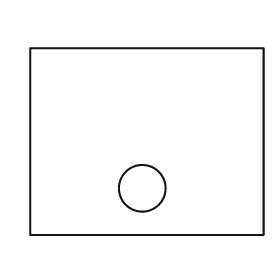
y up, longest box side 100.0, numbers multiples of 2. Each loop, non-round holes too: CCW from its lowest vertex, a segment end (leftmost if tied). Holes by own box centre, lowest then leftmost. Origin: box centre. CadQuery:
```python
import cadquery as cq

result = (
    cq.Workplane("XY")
    .moveTo(-50.0, -40.0)
    .lineTo(50.0, -40.0)
    .lineTo(50.0, 40.0)
    .lineTo(-50.0, 40.0)
    .close()
    .moveTo(-2.0, -20.0)
    .circle(10.0)
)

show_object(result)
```